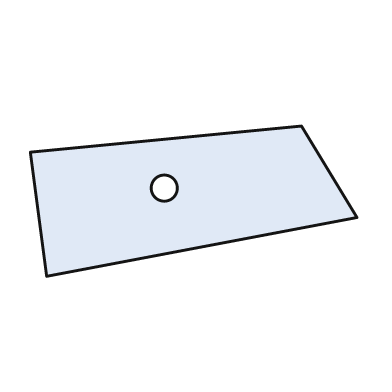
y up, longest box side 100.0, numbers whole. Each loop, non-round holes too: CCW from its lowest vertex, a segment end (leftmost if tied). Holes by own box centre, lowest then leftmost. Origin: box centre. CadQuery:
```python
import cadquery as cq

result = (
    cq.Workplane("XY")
    .moveTo(-45.0, -23.0)
    .lineTo(50.0, -5.0)
    .lineTo(33.0, 23.0)
    .lineTo(-50.0, 15.0)
    .close()
    .moveTo(-9.0, 4.0)
    .circle(4.0)
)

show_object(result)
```